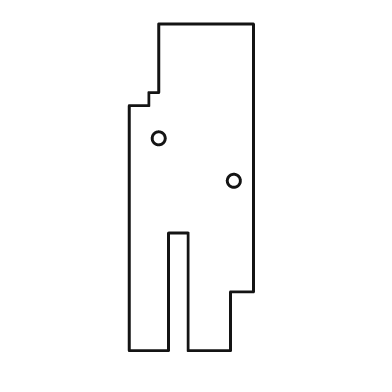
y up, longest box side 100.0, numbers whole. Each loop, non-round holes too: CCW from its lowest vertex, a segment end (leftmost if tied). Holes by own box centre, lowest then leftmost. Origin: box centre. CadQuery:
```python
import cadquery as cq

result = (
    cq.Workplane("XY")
    .moveTo(-19.0, -50.0)
    .lineTo(-7.0, -50.0)
    .lineTo(-7.0, -14.0)
    .lineTo(-1.0, -14.0)
    .lineTo(-1.0, -50.0)
    .lineTo(12.0, -50.0)
    .lineTo(12.0, -32.0)
    .lineTo(19.0, -32.0)
    .lineTo(19.0, 50.0)
    .lineTo(-10.0, 50.0)
    .lineTo(-10.0, 29.0)
    .lineTo(-13.0, 29.0)
    .lineTo(-13.0, 25.0)
    .lineTo(-19.0, 25.0)
    .close()
    .moveTo(13.0, 2.0)
    .circle(2.0)
    .moveTo(-10.0, 15.0)
    .circle(2.0)
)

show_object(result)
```